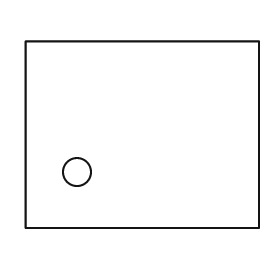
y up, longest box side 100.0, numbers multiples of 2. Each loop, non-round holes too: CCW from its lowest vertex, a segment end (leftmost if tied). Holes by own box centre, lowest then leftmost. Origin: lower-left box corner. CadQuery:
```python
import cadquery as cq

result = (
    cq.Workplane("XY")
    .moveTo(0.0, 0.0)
    .lineTo(100.0, 0.0)
    .lineTo(100.0, 80.0)
    .lineTo(0.0, 80.0)
    .close()
    .moveTo(22.0, 24.0)
    .circle(6.0)
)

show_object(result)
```